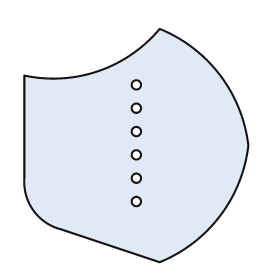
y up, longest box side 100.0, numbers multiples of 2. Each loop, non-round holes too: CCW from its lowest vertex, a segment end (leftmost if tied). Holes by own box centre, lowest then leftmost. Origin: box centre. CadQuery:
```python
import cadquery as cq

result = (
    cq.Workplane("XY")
    .moveTo(10.0, -50.0)
    .threePointArc((36.0, -30.0), (48.0, 0.0))
    .threePointArc((36.0, 30.0), (10.0, 50.0))
    .threePointArc((-16.0, 32.0), (-48.0, 30.0))
    .lineTo(-48.0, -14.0)
    .threePointArc((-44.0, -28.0), (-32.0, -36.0))
    .close()
    .moveTo(0.0, -24.0)
    .circle(2.0)
    .moveTo(0.0, -14.0)
    .circle(2.0)
    .moveTo(0.0, -4.0)
    .circle(2.0)
    .moveTo(0.0, 6.0)
    .circle(2.0)
    .moveTo(0.0, 16.0)
    .circle(2.0)
    .moveTo(0.0, 26.0)
    .circle(2.0)
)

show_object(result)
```